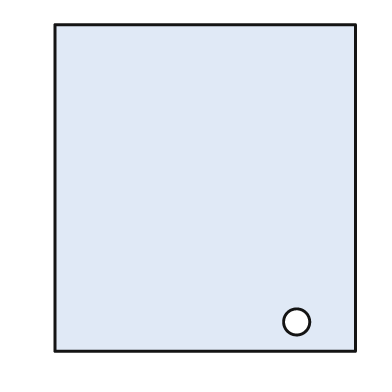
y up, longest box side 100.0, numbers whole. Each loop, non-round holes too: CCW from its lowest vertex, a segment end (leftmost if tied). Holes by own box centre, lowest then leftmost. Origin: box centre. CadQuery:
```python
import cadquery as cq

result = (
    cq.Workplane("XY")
    .moveTo(-46.0, -50.0)
    .lineTo(46.0, -50.0)
    .lineTo(46.0, 50.0)
    .lineTo(-46.0, 50.0)
    .close()
    .moveTo(28.0, -41.0)
    .circle(4.0)
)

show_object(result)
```